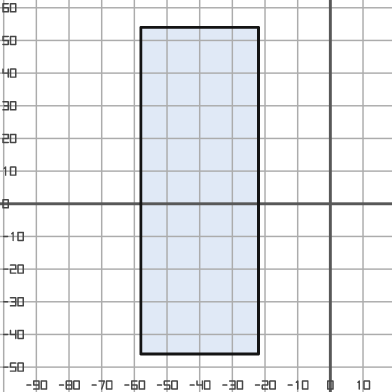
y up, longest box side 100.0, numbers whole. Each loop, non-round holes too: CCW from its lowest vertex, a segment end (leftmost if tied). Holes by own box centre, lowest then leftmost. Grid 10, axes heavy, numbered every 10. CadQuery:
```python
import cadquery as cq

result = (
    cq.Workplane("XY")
    .moveTo(-58.0, -46.0)
    .lineTo(-22.0, -46.0)
    .lineTo(-22.0, 54.0)
    .lineTo(-58.0, 54.0)
    .close()
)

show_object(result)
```